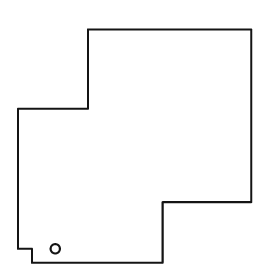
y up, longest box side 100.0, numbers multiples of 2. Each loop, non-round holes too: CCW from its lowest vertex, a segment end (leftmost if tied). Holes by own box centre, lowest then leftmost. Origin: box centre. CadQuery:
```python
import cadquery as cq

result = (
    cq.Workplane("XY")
    .moveTo(-44.0, -50.0)
    .lineTo(12.0, -50.0)
    .lineTo(12.0, -24.0)
    .lineTo(50.0, -24.0)
    .lineTo(50.0, 50.0)
    .lineTo(-20.0, 50.0)
    .lineTo(-20.0, 16.0)
    .lineTo(-50.0, 16.0)
    .lineTo(-50.0, -44.0)
    .lineTo(-44.0, -44.0)
    .close()
    .moveTo(-34.0, -44.0)
    .circle(2.0)
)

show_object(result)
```